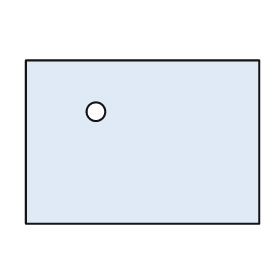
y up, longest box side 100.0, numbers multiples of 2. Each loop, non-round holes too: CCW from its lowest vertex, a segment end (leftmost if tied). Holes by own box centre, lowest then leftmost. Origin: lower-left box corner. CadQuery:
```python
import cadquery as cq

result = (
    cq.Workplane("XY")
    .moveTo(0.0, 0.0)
    .lineTo(100.0, 0.0)
    .lineTo(100.0, 70.0)
    .lineTo(0.0, 70.0)
    .close()
    .moveTo(30.0, 48.0)
    .circle(4.0)
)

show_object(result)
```